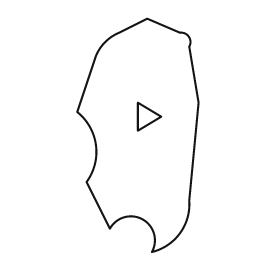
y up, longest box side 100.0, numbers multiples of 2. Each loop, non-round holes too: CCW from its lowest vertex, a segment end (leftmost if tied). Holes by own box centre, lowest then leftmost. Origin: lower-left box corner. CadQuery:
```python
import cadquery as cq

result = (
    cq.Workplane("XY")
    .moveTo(32.0, 0.0)
    .threePointArc((44.0, 8.0), (48.0, 22.0))
    .lineTo(52.0, 64.0)
    .lineTo(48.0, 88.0)
    .threePointArc((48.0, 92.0), (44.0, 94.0))
    .lineTo(30.0, 100.0)
    .lineTo(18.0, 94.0)
    .threePointArc((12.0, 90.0), (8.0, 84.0))
    .lineTo(0.0, 60.0)
    .threePointArc((8.0, 46.0), (4.0, 30.0))
    .lineTo(14.0, 10.0)
    .threePointArc((28.0, 14.0), (32.0, 0.0))
    .close()
    .moveTo(26.0, 52.0)
    .lineTo(36.0, 58.0)
    .lineTo(26.0, 64.0)
    .close()
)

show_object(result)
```